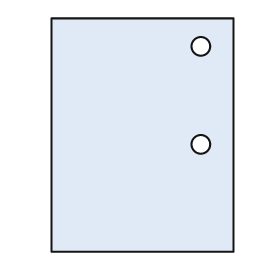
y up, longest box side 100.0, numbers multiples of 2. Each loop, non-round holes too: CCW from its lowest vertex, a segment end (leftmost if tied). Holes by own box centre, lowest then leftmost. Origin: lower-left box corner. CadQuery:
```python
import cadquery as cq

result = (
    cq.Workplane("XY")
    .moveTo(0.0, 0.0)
    .lineTo(78.0, 0.0)
    .lineTo(78.0, 100.0)
    .lineTo(0.0, 100.0)
    .close()
    .moveTo(64.0, 46.0)
    .circle(4.0)
    .moveTo(64.0, 88.0)
    .circle(4.0)
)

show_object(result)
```